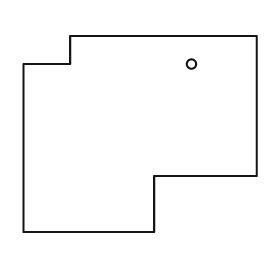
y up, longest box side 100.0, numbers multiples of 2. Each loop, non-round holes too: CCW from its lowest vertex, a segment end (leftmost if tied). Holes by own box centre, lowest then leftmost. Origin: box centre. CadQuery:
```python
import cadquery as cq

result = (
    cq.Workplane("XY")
    .moveTo(-50.0, -42.0)
    .lineTo(6.0, -42.0)
    .lineTo(6.0, -18.0)
    .lineTo(50.0, -18.0)
    .lineTo(50.0, 42.0)
    .lineTo(-30.0, 42.0)
    .lineTo(-30.0, 30.0)
    .lineTo(-50.0, 30.0)
    .close()
    .moveTo(22.0, 30.0)
    .circle(2.0)
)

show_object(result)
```